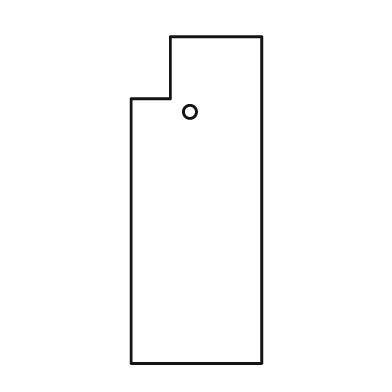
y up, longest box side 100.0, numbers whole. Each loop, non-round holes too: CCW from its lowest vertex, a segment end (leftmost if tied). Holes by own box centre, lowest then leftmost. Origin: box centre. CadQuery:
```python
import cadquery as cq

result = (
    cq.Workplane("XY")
    .moveTo(-20.0, -50.0)
    .lineTo(20.0, -50.0)
    .lineTo(20.0, 50.0)
    .lineTo(-8.0, 50.0)
    .lineTo(-8.0, 31.0)
    .lineTo(-20.0, 31.0)
    .close()
    .moveTo(-2.0, 27.0)
    .circle(2.0)
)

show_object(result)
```